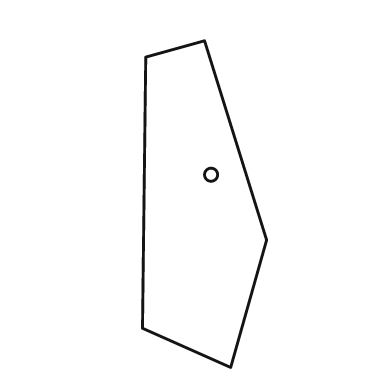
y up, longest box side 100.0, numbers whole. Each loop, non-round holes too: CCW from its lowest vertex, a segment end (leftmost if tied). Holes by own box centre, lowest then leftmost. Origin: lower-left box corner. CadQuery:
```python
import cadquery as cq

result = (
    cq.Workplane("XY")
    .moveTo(27.0, 0.0)
    .lineTo(38.0, 39.0)
    .lineTo(19.0, 100.0)
    .lineTo(1.0, 95.0)
    .lineTo(0.0, 12.0)
    .close()
    .moveTo(21.0, 59.0)
    .circle(2.0)
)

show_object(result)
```